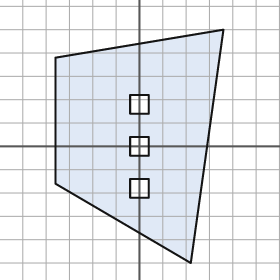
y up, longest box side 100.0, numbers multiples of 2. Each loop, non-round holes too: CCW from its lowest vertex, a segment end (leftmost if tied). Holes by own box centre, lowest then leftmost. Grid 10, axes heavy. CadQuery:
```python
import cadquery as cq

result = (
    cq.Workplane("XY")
    .moveTo(22.0, -50.0)
    .lineTo(36.0, 50.0)
    .lineTo(-36.0, 38.0)
    .lineTo(-36.0, -16.0)
    .close()
    .moveTo(-4.0, -22.0)
    .lineTo(4.0, -22.0)
    .lineTo(4.0, -14.0)
    .lineTo(-4.0, -14.0)
    .close()
    .moveTo(-4.0, -4.0)
    .lineTo(4.0, -4.0)
    .lineTo(4.0, 4.0)
    .lineTo(-4.0, 4.0)
    .close()
    .moveTo(-4.0, 14.0)
    .lineTo(4.0, 14.0)
    .lineTo(4.0, 22.0)
    .lineTo(-4.0, 22.0)
    .close()
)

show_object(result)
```